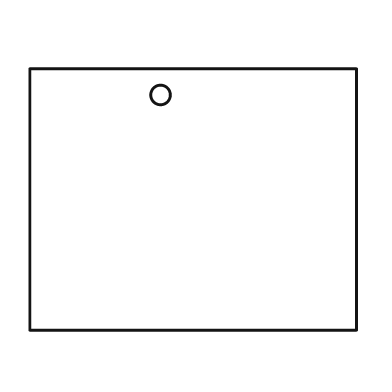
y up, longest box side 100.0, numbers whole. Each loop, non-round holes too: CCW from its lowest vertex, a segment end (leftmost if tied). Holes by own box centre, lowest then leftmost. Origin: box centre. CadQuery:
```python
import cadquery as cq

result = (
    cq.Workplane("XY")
    .moveTo(-50.0, -40.0)
    .lineTo(50.0, -40.0)
    .lineTo(50.0, 40.0)
    .lineTo(-50.0, 40.0)
    .close()
    .moveTo(-10.0, 32.0)
    .circle(3.0)
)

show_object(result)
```